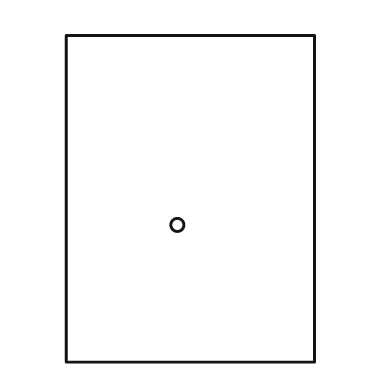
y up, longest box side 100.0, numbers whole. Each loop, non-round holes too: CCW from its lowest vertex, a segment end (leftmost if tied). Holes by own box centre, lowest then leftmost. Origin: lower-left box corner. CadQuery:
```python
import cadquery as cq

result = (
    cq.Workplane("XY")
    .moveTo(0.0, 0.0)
    .lineTo(76.0, 0.0)
    .lineTo(76.0, 100.0)
    .lineTo(0.0, 100.0)
    .close()
    .moveTo(34.0, 42.0)
    .circle(2.0)
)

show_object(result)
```